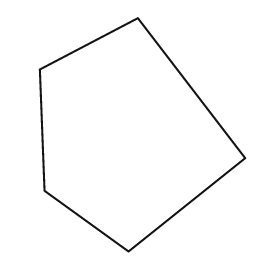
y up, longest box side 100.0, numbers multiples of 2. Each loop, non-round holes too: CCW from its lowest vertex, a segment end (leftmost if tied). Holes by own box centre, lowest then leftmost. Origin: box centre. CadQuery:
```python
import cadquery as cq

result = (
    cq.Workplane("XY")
    .moveTo(-6.0, -50.0)
    .lineTo(44.0, -10.0)
    .lineTo(-2.0, 50.0)
    .lineTo(-44.0, 28.0)
    .lineTo(-42.0, -24.0)
    .close()
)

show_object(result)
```